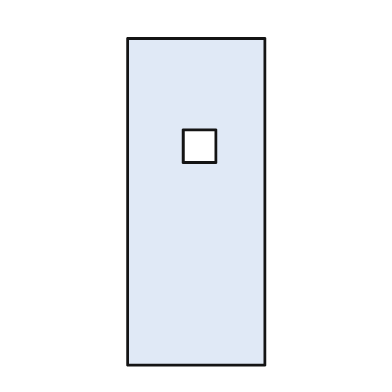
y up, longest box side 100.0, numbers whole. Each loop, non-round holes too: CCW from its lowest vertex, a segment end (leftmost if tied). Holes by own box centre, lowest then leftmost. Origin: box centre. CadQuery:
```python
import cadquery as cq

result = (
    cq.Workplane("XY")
    .moveTo(-21.0, -50.0)
    .lineTo(21.0, -50.0)
    .lineTo(21.0, 50.0)
    .lineTo(-21.0, 50.0)
    .close()
    .moveTo(-4.0, 12.0)
    .lineTo(6.0, 12.0)
    .lineTo(6.0, 22.0)
    .lineTo(-4.0, 22.0)
    .close()
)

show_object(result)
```